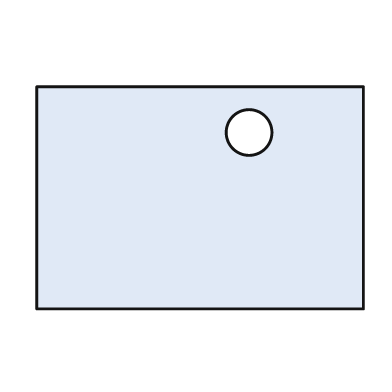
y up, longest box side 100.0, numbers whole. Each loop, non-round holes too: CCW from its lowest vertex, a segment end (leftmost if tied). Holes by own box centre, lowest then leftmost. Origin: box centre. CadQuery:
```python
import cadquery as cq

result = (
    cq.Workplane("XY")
    .moveTo(-50.0, -34.0)
    .lineTo(50.0, -34.0)
    .lineTo(50.0, 34.0)
    .lineTo(-50.0, 34.0)
    .close()
    .moveTo(15.0, 20.0)
    .circle(7.0)
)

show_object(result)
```